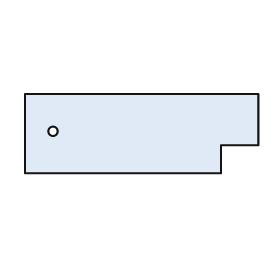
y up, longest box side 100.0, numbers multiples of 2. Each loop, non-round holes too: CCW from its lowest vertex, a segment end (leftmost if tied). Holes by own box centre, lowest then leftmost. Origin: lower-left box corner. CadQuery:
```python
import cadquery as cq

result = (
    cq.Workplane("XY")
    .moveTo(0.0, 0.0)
    .lineTo(84.0, 0.0)
    .lineTo(84.0, 12.0)
    .lineTo(100.0, 12.0)
    .lineTo(100.0, 34.0)
    .lineTo(0.0, 34.0)
    .close()
    .moveTo(12.0, 18.0)
    .circle(2.0)
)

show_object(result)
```